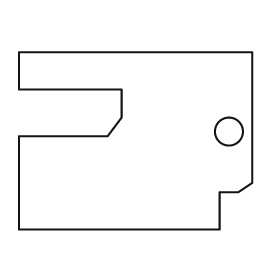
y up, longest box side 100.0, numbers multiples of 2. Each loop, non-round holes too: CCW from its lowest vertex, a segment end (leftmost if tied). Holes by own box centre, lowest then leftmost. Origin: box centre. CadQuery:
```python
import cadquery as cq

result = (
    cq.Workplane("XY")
    .moveTo(-50.0, -38.0)
    .lineTo(36.0, -38.0)
    .lineTo(36.0, -22.0)
    .lineTo(44.0, -22.0)
    .lineTo(50.0, -18.0)
    .lineTo(50.0, 38.0)
    .lineTo(-50.0, 38.0)
    .lineTo(-50.0, 22.0)
    .lineTo(-6.0, 22.0)
    .lineTo(-6.0, 10.0)
    .lineTo(-12.0, 2.0)
    .lineTo(-50.0, 2.0)
    .close()
    .moveTo(40.0, 4.0)
    .circle(6.0)
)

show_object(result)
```